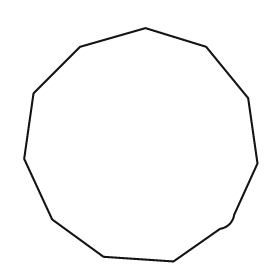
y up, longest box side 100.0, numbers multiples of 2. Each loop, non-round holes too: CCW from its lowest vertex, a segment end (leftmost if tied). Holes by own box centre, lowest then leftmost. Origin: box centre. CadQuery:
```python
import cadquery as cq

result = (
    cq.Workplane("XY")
    .moveTo(14.0, -50.0)
    .lineTo(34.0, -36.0)
    .threePointArc((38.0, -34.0), (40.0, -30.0))
    .lineTo(50.0, -8.0)
    .lineTo(46.0, 20.0)
    .lineTo(28.0, 42.0)
    .lineTo(2.0, 50.0)
    .lineTo(-26.0, 42.0)
    .lineTo(-46.0, 22.0)
    .lineTo(-50.0, -6.0)
    .lineTo(-38.0, -32.0)
    .lineTo(-16.0, -48.0)
    .close()
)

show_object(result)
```